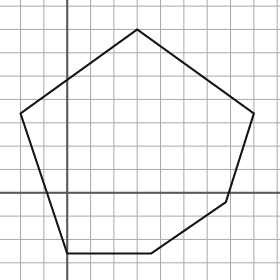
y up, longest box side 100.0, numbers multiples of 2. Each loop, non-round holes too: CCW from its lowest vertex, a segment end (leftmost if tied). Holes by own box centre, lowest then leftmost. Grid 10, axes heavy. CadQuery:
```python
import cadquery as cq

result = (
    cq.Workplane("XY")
    .moveTo(0.0, -26.0)
    .lineTo(36.0, -26.0)
    .lineTo(68.0, -4.0)
    .lineTo(80.0, 34.0)
    .lineTo(30.0, 70.0)
    .lineTo(-20.0, 34.0)
    .close()
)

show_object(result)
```